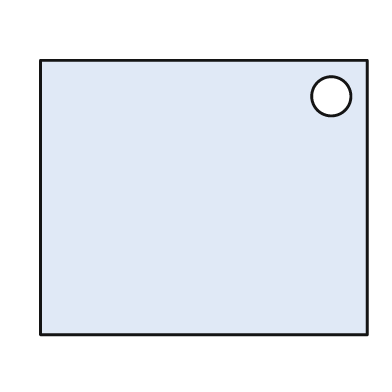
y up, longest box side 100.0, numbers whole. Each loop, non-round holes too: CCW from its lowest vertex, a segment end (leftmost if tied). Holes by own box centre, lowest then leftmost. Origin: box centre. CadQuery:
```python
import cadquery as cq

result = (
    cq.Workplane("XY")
    .moveTo(-50.0, -42.0)
    .lineTo(50.0, -42.0)
    .lineTo(50.0, 42.0)
    .lineTo(-50.0, 42.0)
    .close()
    .moveTo(39.0, 31.0)
    .circle(6.0)
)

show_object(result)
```